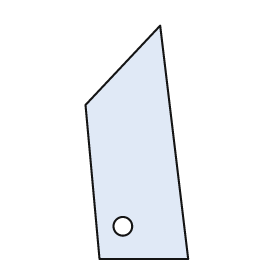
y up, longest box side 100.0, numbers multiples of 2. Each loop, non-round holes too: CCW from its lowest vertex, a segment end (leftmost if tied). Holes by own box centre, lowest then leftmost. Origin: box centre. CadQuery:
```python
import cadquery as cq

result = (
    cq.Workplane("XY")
    .moveTo(-16.0, -50.0)
    .lineTo(22.0, -50.0)
    .lineTo(10.0, 50.0)
    .lineTo(-22.0, 16.0)
    .close()
    .moveTo(-6.0, -36.0)
    .circle(4.0)
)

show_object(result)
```